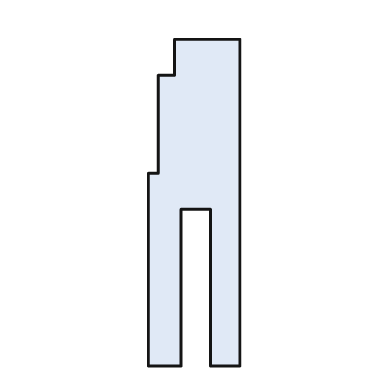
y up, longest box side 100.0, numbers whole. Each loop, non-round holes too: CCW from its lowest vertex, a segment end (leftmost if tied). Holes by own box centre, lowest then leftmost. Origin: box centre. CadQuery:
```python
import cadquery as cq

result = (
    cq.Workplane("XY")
    .moveTo(-14.0, -50.0)
    .lineTo(-4.0, -50.0)
    .lineTo(-4.0, -2.0)
    .lineTo(5.0, -2.0)
    .lineTo(5.0, -50.0)
    .lineTo(14.0, -50.0)
    .lineTo(14.0, 50.0)
    .lineTo(-6.0, 50.0)
    .lineTo(-6.0, 39.0)
    .lineTo(-11.0, 39.0)
    .lineTo(-11.0, 9.0)
    .lineTo(-14.0, 9.0)
    .close()
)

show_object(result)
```